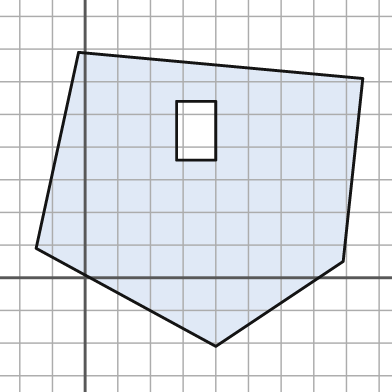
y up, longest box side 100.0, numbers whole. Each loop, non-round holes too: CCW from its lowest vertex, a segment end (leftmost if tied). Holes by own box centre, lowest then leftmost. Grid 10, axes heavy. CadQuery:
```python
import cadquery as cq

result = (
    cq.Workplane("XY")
    .moveTo(40.0, -21.0)
    .lineTo(79.0, 5.0)
    .lineTo(85.0, 61.0)
    .lineTo(-2.0, 69.0)
    .lineTo(-15.0, 9.0)
    .close()
    .moveTo(28.0, 36.0)
    .lineTo(40.0, 36.0)
    .lineTo(40.0, 54.0)
    .lineTo(28.0, 54.0)
    .close()
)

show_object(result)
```